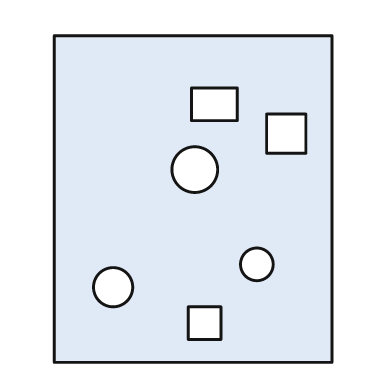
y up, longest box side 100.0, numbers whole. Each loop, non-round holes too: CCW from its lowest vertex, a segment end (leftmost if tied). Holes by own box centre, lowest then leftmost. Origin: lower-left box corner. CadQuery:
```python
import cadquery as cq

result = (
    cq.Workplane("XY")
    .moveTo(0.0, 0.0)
    .lineTo(85.0, 0.0)
    .lineTo(85.0, 100.0)
    .lineTo(0.0, 100.0)
    .close()
    .moveTo(41.0, 7.0)
    .lineTo(51.0, 7.0)
    .lineTo(51.0, 17.0)
    .lineTo(41.0, 17.0)
    .close()
    .moveTo(18.0, 23.0)
    .circle(6.0)
    .moveTo(62.0, 30.0)
    .circle(5.0)
    .moveTo(43.0, 59.0)
    .circle(7.0)
    .moveTo(65.0, 64.0)
    .lineTo(77.0, 64.0)
    .lineTo(77.0, 76.0)
    .lineTo(65.0, 76.0)
    .close()
    .moveTo(42.0, 74.0)
    .lineTo(56.0, 74.0)
    .lineTo(56.0, 84.0)
    .lineTo(42.0, 84.0)
    .close()
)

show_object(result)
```